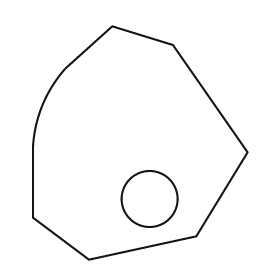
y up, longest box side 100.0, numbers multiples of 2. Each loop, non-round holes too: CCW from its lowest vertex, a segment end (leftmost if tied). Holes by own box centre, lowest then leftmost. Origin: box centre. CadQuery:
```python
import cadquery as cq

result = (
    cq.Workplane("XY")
    .moveTo(-22.0, -50.0)
    .lineTo(24.0, -40.0)
    .lineTo(46.0, -4.0)
    .lineTo(14.0, 42.0)
    .lineTo(-12.0, 50.0)
    .lineTo(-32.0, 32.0)
    .threePointArc((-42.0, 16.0), (-46.0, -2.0))
    .lineTo(-46.0, -32.0)
    .close()
    .moveTo(4.0, -24.0)
    .circle(12.0)
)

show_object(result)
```